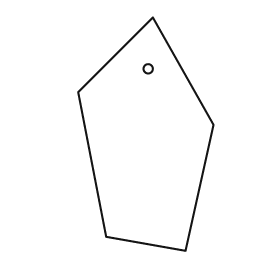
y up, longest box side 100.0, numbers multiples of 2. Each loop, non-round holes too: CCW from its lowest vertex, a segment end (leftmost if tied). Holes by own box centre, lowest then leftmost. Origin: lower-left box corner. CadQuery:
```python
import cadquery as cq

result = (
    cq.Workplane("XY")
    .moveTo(46.0, 0.0)
    .lineTo(58.0, 54.0)
    .lineTo(32.0, 100.0)
    .lineTo(0.0, 68.0)
    .lineTo(12.0, 6.0)
    .close()
    .moveTo(30.0, 78.0)
    .circle(2.0)
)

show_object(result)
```